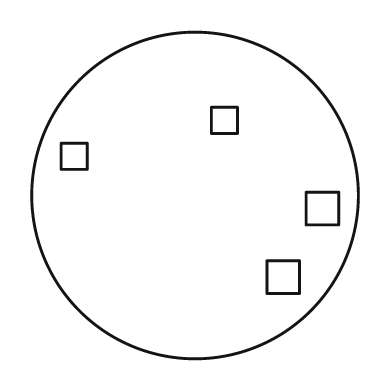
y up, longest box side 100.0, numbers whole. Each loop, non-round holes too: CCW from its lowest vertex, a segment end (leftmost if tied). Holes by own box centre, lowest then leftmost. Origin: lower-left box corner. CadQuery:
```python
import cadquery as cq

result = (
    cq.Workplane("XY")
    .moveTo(50.0, 50.0)
    .circle(50.0)
    .moveTo(72.0, 20.0)
    .lineTo(82.0, 20.0)
    .lineTo(82.0, 30.0)
    .lineTo(72.0, 30.0)
    .close()
    .moveTo(84.0, 41.0)
    .lineTo(94.0, 41.0)
    .lineTo(94.0, 51.0)
    .lineTo(84.0, 51.0)
    .close()
    .moveTo(9.0, 58.0)
    .lineTo(17.0, 58.0)
    .lineTo(17.0, 66.0)
    .lineTo(9.0, 66.0)
    .close()
    .moveTo(55.0, 69.0)
    .lineTo(63.0, 69.0)
    .lineTo(63.0, 77.0)
    .lineTo(55.0, 77.0)
    .close()
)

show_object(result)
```